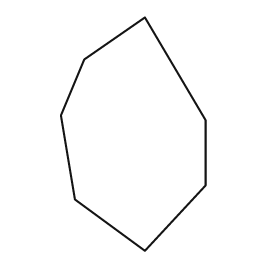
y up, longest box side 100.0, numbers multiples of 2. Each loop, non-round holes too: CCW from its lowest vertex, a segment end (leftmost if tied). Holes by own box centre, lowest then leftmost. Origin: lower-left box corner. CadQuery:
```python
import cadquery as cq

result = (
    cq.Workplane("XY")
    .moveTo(36.0, 0.0)
    .lineTo(62.0, 28.0)
    .lineTo(62.0, 56.0)
    .lineTo(36.0, 100.0)
    .lineTo(10.0, 82.0)
    .lineTo(0.0, 58.0)
    .lineTo(6.0, 22.0)
    .close()
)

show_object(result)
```